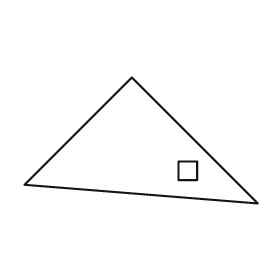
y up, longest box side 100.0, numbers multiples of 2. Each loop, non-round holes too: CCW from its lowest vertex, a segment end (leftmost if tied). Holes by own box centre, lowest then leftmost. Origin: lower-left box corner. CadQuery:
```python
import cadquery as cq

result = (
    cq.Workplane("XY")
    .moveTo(100.0, 0.0)
    .lineTo(46.0, 54.0)
    .lineTo(0.0, 8.0)
    .close()
    .moveTo(66.0, 10.0)
    .lineTo(74.0, 10.0)
    .lineTo(74.0, 18.0)
    .lineTo(66.0, 18.0)
    .close()
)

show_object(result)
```